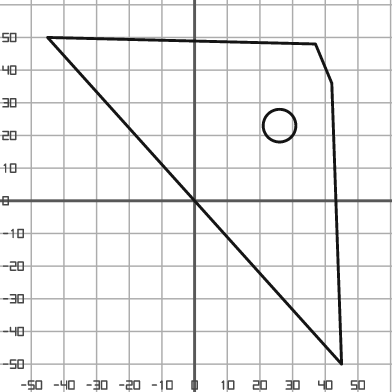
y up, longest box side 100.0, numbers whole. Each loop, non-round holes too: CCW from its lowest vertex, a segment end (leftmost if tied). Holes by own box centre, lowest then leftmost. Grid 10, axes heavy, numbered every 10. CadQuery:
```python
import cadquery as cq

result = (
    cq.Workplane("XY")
    .moveTo(45.0, -50.0)
    .lineTo(42.0, 36.0)
    .lineTo(37.0, 48.0)
    .lineTo(-45.0, 50.0)
    .close()
    .moveTo(26.0, 23.0)
    .circle(5.0)
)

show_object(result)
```